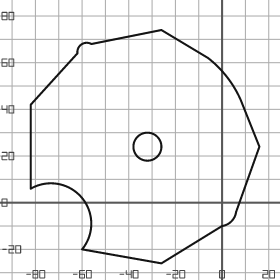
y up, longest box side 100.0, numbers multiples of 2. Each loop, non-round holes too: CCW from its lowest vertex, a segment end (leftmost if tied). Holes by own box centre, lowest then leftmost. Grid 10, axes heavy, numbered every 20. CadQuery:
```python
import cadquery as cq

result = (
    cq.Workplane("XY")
    .moveTo(-26.0, -26.0)
    .lineTo(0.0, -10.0)
    .threePointArc((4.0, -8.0), (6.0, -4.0))
    .lineTo(16.0, 24.0)
    .lineTo(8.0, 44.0)
    .threePointArc((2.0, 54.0), (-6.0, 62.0))
    .lineTo(-26.0, 74.0)
    .lineTo(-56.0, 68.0)
    .threePointArc((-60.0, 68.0), (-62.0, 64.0))
    .lineTo(-82.0, 42.0)
    .lineTo(-82.0, 6.0)
    .threePointArc((-60.0, 2.0), (-60.0, -20.0))
    .close()
    .moveTo(-32.0, 24.0)
    .circle(6.0)
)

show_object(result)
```